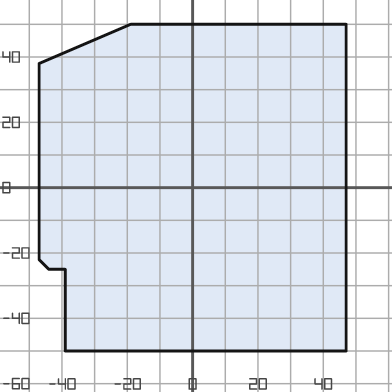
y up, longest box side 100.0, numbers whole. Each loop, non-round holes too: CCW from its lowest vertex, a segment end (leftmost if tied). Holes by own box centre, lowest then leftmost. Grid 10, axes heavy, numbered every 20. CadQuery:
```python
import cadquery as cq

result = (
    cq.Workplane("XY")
    .moveTo(-39.0, -50.0)
    .lineTo(47.0, -50.0)
    .lineTo(47.0, 50.0)
    .lineTo(-19.0, 50.0)
    .lineTo(-47.0, 38.0)
    .lineTo(-47.0, -22.0)
    .lineTo(-44.0, -25.0)
    .lineTo(-39.0, -25.0)
    .close()
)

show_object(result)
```